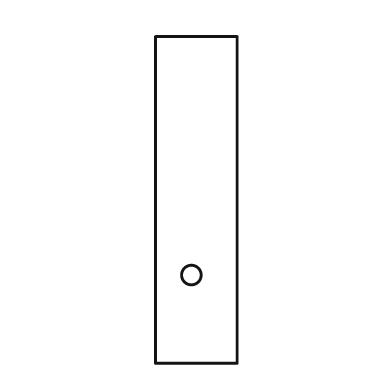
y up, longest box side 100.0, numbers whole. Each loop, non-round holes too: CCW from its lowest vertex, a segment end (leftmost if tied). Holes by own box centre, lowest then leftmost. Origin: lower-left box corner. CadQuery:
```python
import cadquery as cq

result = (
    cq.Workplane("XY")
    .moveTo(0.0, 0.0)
    .lineTo(25.0, 0.0)
    .lineTo(25.0, 100.0)
    .lineTo(0.0, 100.0)
    .close()
    .moveTo(11.0, 27.0)
    .circle(3.0)
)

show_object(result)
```